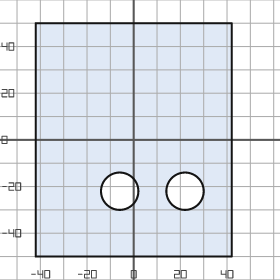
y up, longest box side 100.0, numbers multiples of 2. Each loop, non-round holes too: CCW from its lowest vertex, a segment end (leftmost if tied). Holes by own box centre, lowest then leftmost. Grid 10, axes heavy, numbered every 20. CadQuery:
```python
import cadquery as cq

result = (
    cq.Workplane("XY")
    .moveTo(-42.0, -50.0)
    .lineTo(42.0, -50.0)
    .lineTo(42.0, 50.0)
    .lineTo(-42.0, 50.0)
    .close()
    .moveTo(-6.0, -22.0)
    .circle(8.0)
    .moveTo(22.0, -22.0)
    .circle(8.0)
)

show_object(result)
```